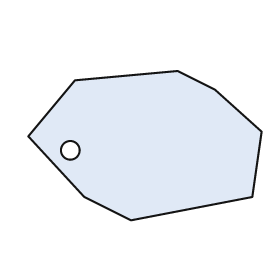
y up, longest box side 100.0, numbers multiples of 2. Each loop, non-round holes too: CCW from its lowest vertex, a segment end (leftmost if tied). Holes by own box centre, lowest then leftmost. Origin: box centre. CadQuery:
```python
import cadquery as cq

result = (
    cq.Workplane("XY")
    .moveTo(-6.0, -32.0)
    .lineTo(46.0, -22.0)
    .lineTo(50.0, 6.0)
    .lineTo(30.0, 24.0)
    .lineTo(14.0, 32.0)
    .lineTo(-30.0, 28.0)
    .lineTo(-50.0, 4.0)
    .lineTo(-26.0, -22.0)
    .close()
    .moveTo(-32.0, -2.0)
    .circle(4.0)
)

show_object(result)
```